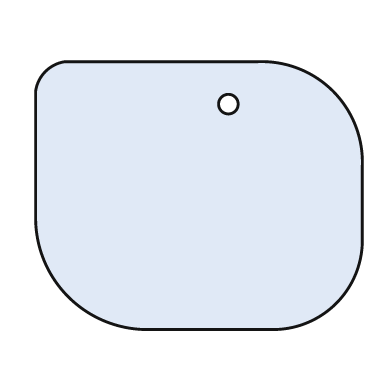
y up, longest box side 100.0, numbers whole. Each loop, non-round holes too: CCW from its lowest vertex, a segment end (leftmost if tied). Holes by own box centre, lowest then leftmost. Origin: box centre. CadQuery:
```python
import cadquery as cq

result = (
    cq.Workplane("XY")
    .moveTo(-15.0, -41.0)
    .lineTo(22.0, -41.0)
    .threePointArc((42.0, -33.0), (50.0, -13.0))
    .lineTo(50.0, 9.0)
    .threePointArc((41.0, 32.0), (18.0, 41.0))
    .lineTo(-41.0, 41.0)
    .threePointArc((-47.0, 38.0), (-50.0, 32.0))
    .lineTo(-50.0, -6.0)
    .threePointArc((-40.0, -31.0), (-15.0, -41.0))
    .close()
    .moveTo(9.0, 28.0)
    .circle(3.0)
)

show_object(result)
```